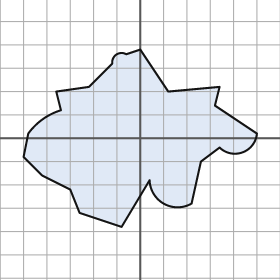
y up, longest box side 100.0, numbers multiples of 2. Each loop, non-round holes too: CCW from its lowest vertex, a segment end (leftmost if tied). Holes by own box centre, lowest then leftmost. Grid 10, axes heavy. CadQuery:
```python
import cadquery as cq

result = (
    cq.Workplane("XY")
    .moveTo(-8.0, -38.0)
    .lineTo(4.0, -18.0)
    .threePointArc((10.0, -28.0), (22.0, -28.0))
    .lineTo(26.0, -10.0)
    .lineTo(34.0, -4.0)
    .threePointArc((44.0, -6.0), (50.0, 2.0))
    .lineTo(32.0, 14.0)
    .lineTo(34.0, 22.0)
    .lineTo(12.0, 20.0)
    .lineTo(0.0, 38.0)
    .lineTo(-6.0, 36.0)
    .threePointArc((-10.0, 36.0), (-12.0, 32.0))
    .lineTo(-22.0, 22.0)
    .lineTo(-36.0, 20.0)
    .lineTo(-34.0, 12.0)
    .threePointArc((-42.0, 8.0), (-48.0, 2.0))
    .lineTo(-50.0, -8.0)
    .lineTo(-42.0, -16.0)
    .lineTo(-30.0, -22.0)
    .lineTo(-26.0, -32.0)
    .close()
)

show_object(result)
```